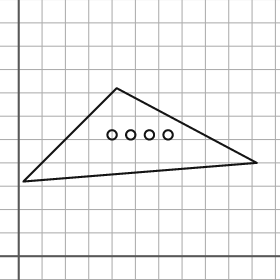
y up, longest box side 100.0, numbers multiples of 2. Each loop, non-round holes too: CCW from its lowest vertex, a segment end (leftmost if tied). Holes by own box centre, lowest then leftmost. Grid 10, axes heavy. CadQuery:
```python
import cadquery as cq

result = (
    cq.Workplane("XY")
    .moveTo(2.0, 32.0)
    .lineTo(102.0, 40.0)
    .lineTo(42.0, 72.0)
    .close()
    .moveTo(40.0, 52.0)
    .circle(2.0)
    .moveTo(48.0, 52.0)
    .circle(2.0)
    .moveTo(56.0, 52.0)
    .circle(2.0)
    .moveTo(64.0, 52.0)
    .circle(2.0)
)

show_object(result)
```